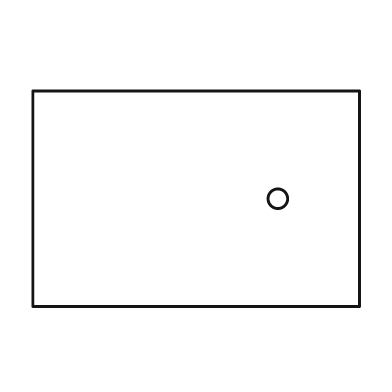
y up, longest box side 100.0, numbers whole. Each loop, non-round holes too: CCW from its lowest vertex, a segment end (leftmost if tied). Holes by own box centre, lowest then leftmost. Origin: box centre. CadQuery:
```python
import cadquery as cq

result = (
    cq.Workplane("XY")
    .moveTo(-50.0, -33.0)
    .lineTo(50.0, -33.0)
    .lineTo(50.0, 33.0)
    .lineTo(-50.0, 33.0)
    .close()
    .moveTo(25.0, 0.0)
    .circle(3.0)
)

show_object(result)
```